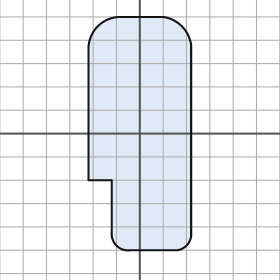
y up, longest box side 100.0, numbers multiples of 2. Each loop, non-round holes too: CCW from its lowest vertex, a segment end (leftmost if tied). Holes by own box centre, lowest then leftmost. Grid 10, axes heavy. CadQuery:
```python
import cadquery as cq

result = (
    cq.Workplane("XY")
    .moveTo(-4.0, -50.0)
    .lineTo(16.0, -50.0)
    .threePointArc((20.0, -48.0), (22.0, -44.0))
    .lineTo(22.0, 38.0)
    .threePointArc((18.0, 46.0), (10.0, 50.0))
    .lineTo(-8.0, 50.0)
    .threePointArc((-18.0, 46.0), (-22.0, 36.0))
    .lineTo(-22.0, -20.0)
    .lineTo(-12.0, -20.0)
    .lineTo(-12.0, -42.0)
    .threePointArc((-10.0, -48.0), (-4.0, -50.0))
    .close()
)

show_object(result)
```